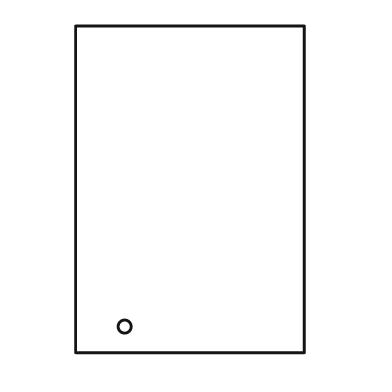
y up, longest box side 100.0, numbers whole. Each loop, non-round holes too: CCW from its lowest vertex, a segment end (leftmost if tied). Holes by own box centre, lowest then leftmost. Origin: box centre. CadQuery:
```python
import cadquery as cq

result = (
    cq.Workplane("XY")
    .moveTo(-35.0, -50.0)
    .lineTo(35.0, -50.0)
    .lineTo(35.0, 50.0)
    .lineTo(-35.0, 50.0)
    .close()
    .moveTo(-20.0, -42.0)
    .circle(2.0)
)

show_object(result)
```